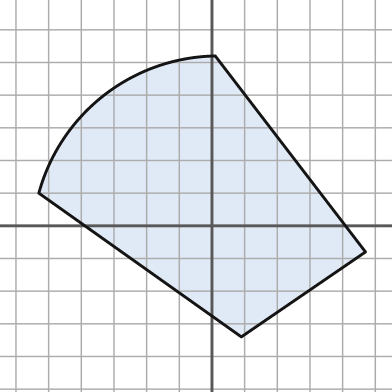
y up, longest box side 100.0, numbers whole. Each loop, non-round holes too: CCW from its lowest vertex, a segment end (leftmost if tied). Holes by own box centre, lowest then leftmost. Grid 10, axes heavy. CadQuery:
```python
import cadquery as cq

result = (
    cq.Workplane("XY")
    .moveTo(9.0, -34.0)
    .lineTo(47.0, -8.0)
    .lineTo(1.0, 52.0)
    .threePointArc((-33.0, 40.0), (-53.0, 10.0))
    .close()
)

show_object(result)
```